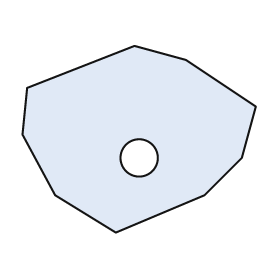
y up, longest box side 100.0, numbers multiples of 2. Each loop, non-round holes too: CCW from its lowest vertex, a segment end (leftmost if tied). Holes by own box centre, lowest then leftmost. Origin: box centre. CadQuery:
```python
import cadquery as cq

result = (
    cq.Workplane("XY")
    .moveTo(-10.0, -40.0)
    .lineTo(28.0, -24.0)
    .lineTo(44.0, -8.0)
    .lineTo(50.0, 14.0)
    .lineTo(20.0, 34.0)
    .lineTo(-2.0, 40.0)
    .lineTo(-48.0, 22.0)
    .lineTo(-50.0, 2.0)
    .lineTo(-36.0, -24.0)
    .close()
    .moveTo(0.0, -8.0)
    .circle(8.0)
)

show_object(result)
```